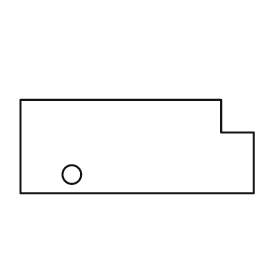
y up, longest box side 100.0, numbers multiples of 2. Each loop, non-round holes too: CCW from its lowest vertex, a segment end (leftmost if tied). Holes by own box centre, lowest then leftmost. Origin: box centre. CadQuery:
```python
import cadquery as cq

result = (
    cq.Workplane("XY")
    .moveTo(-50.0, -20.0)
    .lineTo(50.0, -20.0)
    .lineTo(50.0, 6.0)
    .lineTo(36.0, 6.0)
    .lineTo(36.0, 20.0)
    .lineTo(-50.0, 20.0)
    .close()
    .moveTo(-28.0, -12.0)
    .circle(4.0)
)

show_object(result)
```